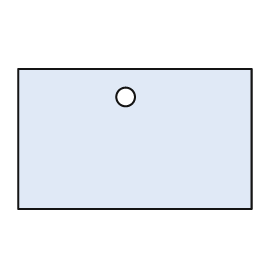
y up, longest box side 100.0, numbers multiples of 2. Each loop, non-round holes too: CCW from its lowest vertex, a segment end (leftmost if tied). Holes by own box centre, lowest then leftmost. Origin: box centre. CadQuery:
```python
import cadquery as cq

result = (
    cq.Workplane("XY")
    .moveTo(-50.0, -30.0)
    .lineTo(50.0, -30.0)
    .lineTo(50.0, 30.0)
    .lineTo(-50.0, 30.0)
    .close()
    .moveTo(-4.0, 18.0)
    .circle(4.0)
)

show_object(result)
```